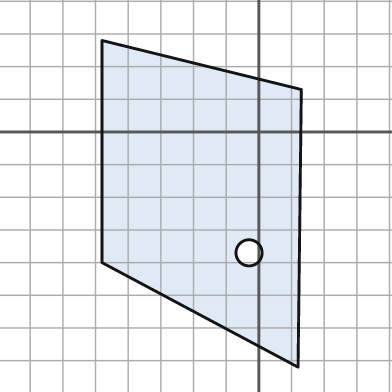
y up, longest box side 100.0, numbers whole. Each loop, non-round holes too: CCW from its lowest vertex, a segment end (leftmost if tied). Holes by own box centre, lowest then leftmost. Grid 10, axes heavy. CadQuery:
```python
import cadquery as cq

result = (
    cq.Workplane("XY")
    .moveTo(12.0, -72.0)
    .lineTo(13.0, 13.0)
    .lineTo(-48.0, 28.0)
    .lineTo(-48.0, -40.0)
    .close()
    .moveTo(-3.0, -37.0)
    .circle(4.0)
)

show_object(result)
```